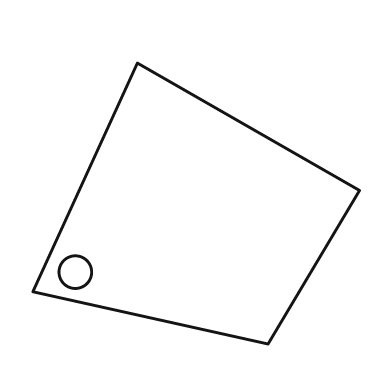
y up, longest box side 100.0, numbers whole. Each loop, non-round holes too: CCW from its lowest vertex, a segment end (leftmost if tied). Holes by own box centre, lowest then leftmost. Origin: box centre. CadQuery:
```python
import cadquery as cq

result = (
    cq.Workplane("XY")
    .moveTo(22.0, -43.0)
    .lineTo(50.0, 4.0)
    .lineTo(-18.0, 43.0)
    .lineTo(-50.0, -27.0)
    .close()
    .moveTo(-37.0, -21.0)
    .circle(5.0)
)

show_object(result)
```